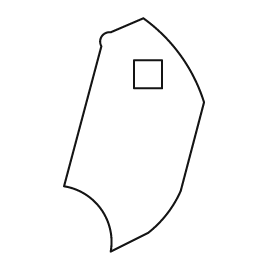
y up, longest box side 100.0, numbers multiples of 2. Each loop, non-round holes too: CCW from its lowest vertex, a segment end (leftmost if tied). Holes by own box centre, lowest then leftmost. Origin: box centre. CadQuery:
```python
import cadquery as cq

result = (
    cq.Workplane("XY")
    .moveTo(-10.0, -50.0)
    .lineTo(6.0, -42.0)
    .threePointArc((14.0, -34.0), (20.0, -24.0))
    .lineTo(30.0, 14.0)
    .threePointArc((20.0, 34.0), (4.0, 50.0))
    .lineTo(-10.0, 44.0)
    .threePointArc((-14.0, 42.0), (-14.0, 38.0))
    .lineTo(-30.0, -22.0)
    .threePointArc((-14.0, -32.0), (-10.0, -50.0))
    .close()
    .moveTo(0.0, 20.0)
    .lineTo(12.0, 20.0)
    .lineTo(12.0, 32.0)
    .lineTo(0.0, 32.0)
    .close()
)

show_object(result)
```